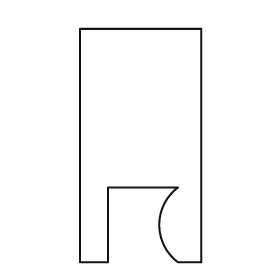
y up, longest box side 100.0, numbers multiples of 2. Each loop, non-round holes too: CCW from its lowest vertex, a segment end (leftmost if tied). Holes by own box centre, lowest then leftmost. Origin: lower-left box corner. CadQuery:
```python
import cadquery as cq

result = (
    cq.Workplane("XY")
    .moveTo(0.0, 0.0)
    .lineTo(12.0, 0.0)
    .lineTo(12.0, 32.0)
    .lineTo(42.0, 32.0)
    .threePointArc((34.0, 16.0), (42.0, 0.0))
    .lineTo(52.0, 0.0)
    .lineTo(52.0, 100.0)
    .lineTo(0.0, 100.0)
    .close()
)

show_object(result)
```